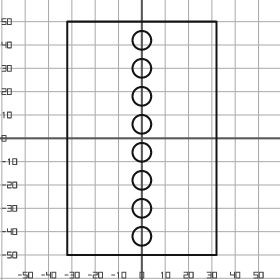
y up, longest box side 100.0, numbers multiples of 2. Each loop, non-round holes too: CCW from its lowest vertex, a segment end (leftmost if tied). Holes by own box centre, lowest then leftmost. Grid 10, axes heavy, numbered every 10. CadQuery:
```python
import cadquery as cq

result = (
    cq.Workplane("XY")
    .moveTo(-32.0, -50.0)
    .lineTo(32.0, -50.0)
    .lineTo(32.0, 50.0)
    .lineTo(-32.0, 50.0)
    .close()
    .moveTo(0.0, -42.0)
    .circle(4.0)
    .moveTo(0.0, -30.0)
    .circle(4.0)
    .moveTo(0.0, -18.0)
    .circle(4.0)
    .moveTo(0.0, -6.0)
    .circle(4.0)
    .moveTo(0.0, 6.0)
    .circle(4.0)
    .moveTo(0.0, 18.0)
    .circle(4.0)
    .moveTo(0.0, 30.0)
    .circle(4.0)
    .moveTo(0.0, 42.0)
    .circle(4.0)
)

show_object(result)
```